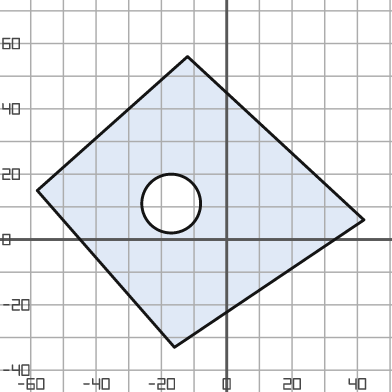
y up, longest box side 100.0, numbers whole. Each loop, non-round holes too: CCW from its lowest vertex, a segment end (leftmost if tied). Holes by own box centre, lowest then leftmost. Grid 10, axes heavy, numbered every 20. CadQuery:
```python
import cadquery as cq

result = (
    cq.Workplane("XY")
    .moveTo(-16.0, -33.0)
    .lineTo(42.0, 6.0)
    .lineTo(-12.0, 56.0)
    .lineTo(-58.0, 15.0)
    .close()
    .moveTo(-17.0, 11.0)
    .circle(9.0)
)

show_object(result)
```